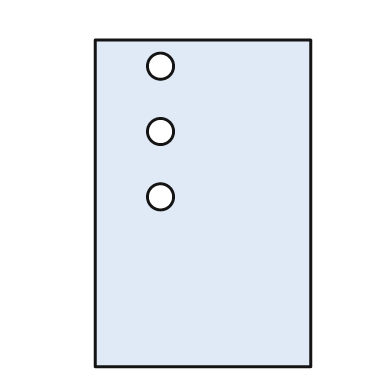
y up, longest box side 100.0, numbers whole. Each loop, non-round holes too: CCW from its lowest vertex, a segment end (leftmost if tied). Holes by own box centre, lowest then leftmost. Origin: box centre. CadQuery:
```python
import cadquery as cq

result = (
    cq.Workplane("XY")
    .moveTo(-33.0, -50.0)
    .lineTo(33.0, -50.0)
    .lineTo(33.0, 50.0)
    .lineTo(-33.0, 50.0)
    .close()
    .moveTo(-13.0, 2.0)
    .circle(4.0)
    .moveTo(-13.0, 22.0)
    .circle(4.0)
    .moveTo(-13.0, 42.0)
    .circle(4.0)
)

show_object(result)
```